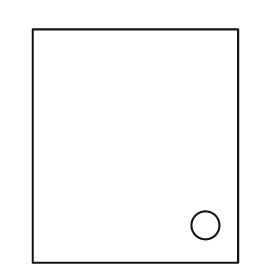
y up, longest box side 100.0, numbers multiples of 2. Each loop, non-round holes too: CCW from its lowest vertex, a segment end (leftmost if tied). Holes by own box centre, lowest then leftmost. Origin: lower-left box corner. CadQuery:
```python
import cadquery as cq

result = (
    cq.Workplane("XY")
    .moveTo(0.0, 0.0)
    .lineTo(88.0, 0.0)
    .lineTo(88.0, 100.0)
    .lineTo(0.0, 100.0)
    .close()
    .moveTo(74.0, 16.0)
    .circle(6.0)
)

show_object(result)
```